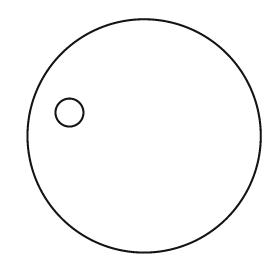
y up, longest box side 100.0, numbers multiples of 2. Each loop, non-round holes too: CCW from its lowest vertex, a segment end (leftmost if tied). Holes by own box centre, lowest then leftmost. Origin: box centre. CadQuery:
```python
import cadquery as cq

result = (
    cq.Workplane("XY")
    .moveTo(0.0, 0.0)
    .circle(50.0)
    .moveTo(-32.0, 10.0)
    .circle(6.0)
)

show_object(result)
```